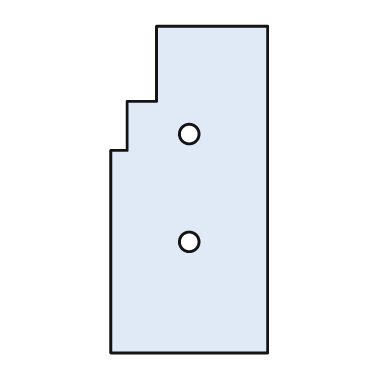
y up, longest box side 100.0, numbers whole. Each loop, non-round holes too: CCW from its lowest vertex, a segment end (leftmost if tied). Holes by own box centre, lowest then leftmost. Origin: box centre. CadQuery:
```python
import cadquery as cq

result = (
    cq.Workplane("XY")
    .moveTo(-24.0, -50.0)
    .lineTo(24.0, -50.0)
    .lineTo(24.0, 50.0)
    .lineTo(-10.0, 50.0)
    .lineTo(-10.0, 27.0)
    .lineTo(-19.0, 27.0)
    .lineTo(-19.0, 12.0)
    .lineTo(-24.0, 12.0)
    .close()
    .moveTo(0.0, -16.0)
    .circle(3.0)
    .moveTo(0.0, 17.0)
    .circle(3.0)
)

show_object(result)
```